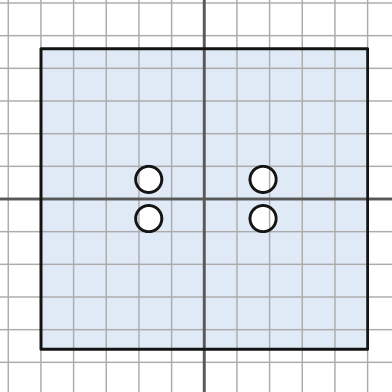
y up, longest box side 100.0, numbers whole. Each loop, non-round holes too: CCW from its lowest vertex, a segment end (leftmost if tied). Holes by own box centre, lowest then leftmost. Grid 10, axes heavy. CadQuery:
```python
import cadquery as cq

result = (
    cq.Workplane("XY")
    .moveTo(-50.0, -46.0)
    .lineTo(50.0, -46.0)
    .lineTo(50.0, 46.0)
    .lineTo(-50.0, 46.0)
    .close()
    .moveTo(-17.0, -6.0)
    .circle(4.0)
    .moveTo(18.0, -6.0)
    .circle(4.0)
    .moveTo(-17.0, 6.0)
    .circle(4.0)
    .moveTo(18.0, 6.0)
    .circle(4.0)
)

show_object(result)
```